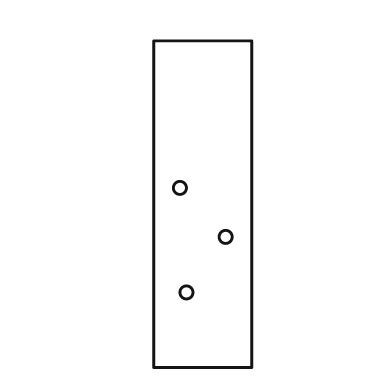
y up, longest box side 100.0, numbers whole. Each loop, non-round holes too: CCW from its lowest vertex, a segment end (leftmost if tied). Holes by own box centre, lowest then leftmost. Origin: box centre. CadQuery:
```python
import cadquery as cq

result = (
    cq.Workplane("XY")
    .moveTo(-15.0, -50.0)
    .lineTo(15.0, -50.0)
    .lineTo(15.0, 50.0)
    .lineTo(-15.0, 50.0)
    .close()
    .moveTo(-5.0, -27.0)
    .circle(2.0)
    .moveTo(7.0, -10.0)
    .circle(2.0)
    .moveTo(-7.0, 5.0)
    .circle(2.0)
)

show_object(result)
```